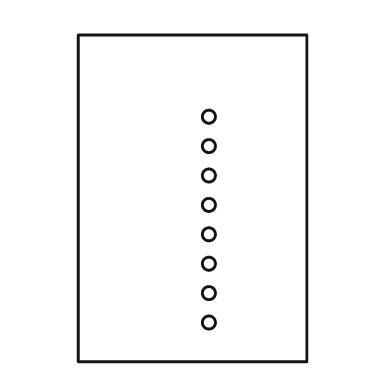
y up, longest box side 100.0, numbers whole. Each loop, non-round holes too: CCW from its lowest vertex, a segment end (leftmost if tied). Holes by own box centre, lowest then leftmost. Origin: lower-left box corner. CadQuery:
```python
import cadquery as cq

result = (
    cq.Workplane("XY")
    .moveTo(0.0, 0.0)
    .lineTo(70.0, 0.0)
    .lineTo(70.0, 100.0)
    .lineTo(0.0, 100.0)
    .close()
    .moveTo(40.0, 12.0)
    .circle(2.0)
    .moveTo(40.0, 21.0)
    .circle(2.0)
    .moveTo(40.0, 30.0)
    .circle(2.0)
    .moveTo(40.0, 39.0)
    .circle(2.0)
    .moveTo(40.0, 48.0)
    .circle(2.0)
    .moveTo(40.0, 57.0)
    .circle(2.0)
    .moveTo(40.0, 66.0)
    .circle(2.0)
    .moveTo(40.0, 75.0)
    .circle(2.0)
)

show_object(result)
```